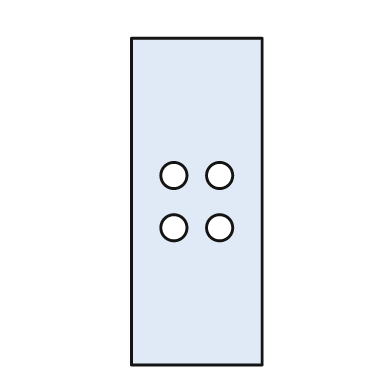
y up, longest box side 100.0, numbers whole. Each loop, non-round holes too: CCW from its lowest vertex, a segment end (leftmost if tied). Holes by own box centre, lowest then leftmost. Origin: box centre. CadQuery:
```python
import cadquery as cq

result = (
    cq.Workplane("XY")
    .moveTo(-20.0, -50.0)
    .lineTo(20.0, -50.0)
    .lineTo(20.0, 50.0)
    .lineTo(-20.0, 50.0)
    .close()
    .moveTo(-7.0, -8.0)
    .circle(4.0)
    .moveTo(7.0, -8.0)
    .circle(4.0)
    .moveTo(-7.0, 8.0)
    .circle(4.0)
    .moveTo(7.0, 8.0)
    .circle(4.0)
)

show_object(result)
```